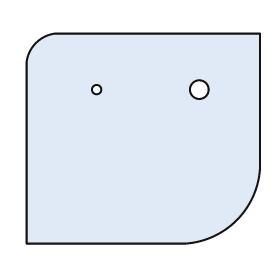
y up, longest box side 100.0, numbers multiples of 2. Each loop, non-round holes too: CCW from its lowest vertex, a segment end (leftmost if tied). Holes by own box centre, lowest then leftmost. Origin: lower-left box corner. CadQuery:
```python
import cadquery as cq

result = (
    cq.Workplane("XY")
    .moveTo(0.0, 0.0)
    .lineTo(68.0, 0.0)
    .threePointArc((90.0, 10.0), (100.0, 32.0))
    .lineTo(100.0, 90.0)
    .lineTo(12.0, 90.0)
    .threePointArc((4.0, 86.0), (0.0, 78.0))
    .close()
    .moveTo(30.0, 66.0)
    .circle(2.0)
    .moveTo(74.0, 66.0)
    .circle(4.0)
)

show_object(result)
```